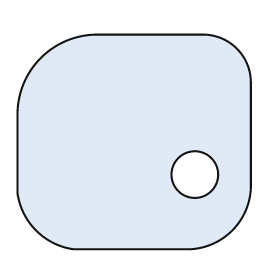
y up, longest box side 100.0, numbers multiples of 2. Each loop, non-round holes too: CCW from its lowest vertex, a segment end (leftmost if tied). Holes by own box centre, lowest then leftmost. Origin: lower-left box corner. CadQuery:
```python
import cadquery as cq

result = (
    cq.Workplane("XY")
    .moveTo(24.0, 0.0)
    .lineTo(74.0, 0.0)
    .threePointArc((92.0, 8.0), (100.0, 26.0))
    .lineTo(100.0, 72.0)
    .threePointArc((94.0, 86.0), (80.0, 92.0))
    .lineTo(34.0, 92.0)
    .threePointArc((10.0, 82.0), (0.0, 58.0))
    .lineTo(0.0, 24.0)
    .threePointArc((8.0, 8.0), (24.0, 0.0))
    .close()
    .moveTo(76.0, 32.0)
    .circle(10.0)
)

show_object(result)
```